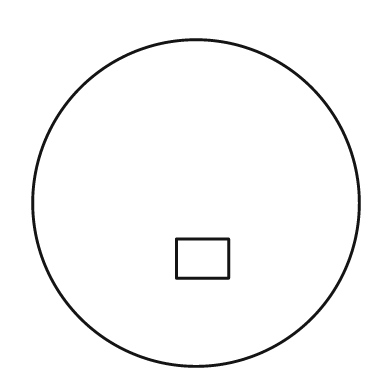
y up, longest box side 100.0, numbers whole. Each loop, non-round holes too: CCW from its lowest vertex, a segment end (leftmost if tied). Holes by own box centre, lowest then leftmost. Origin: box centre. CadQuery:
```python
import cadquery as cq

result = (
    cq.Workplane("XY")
    .moveTo(0.0, 0.0)
    .circle(50.0)
    .moveTo(-6.0, -23.0)
    .lineTo(10.0, -23.0)
    .lineTo(10.0, -11.0)
    .lineTo(-6.0, -11.0)
    .close()
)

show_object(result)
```